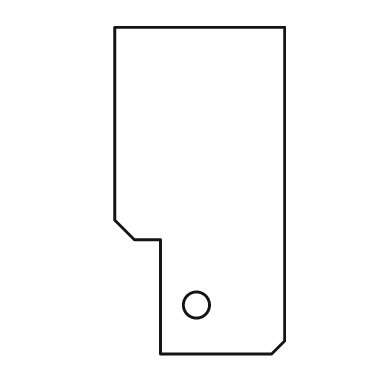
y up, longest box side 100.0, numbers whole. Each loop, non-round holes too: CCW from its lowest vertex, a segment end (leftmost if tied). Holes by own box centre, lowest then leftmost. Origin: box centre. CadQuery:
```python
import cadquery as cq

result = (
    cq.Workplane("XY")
    .moveTo(-12.0, -50.0)
    .lineTo(22.0, -50.0)
    .lineTo(26.0, -46.0)
    .lineTo(26.0, 50.0)
    .lineTo(-26.0, 50.0)
    .lineTo(-26.0, -9.0)
    .lineTo(-20.0, -15.0)
    .lineTo(-12.0, -15.0)
    .close()
    .moveTo(-1.0, -35.0)
    .circle(4.0)
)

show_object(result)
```